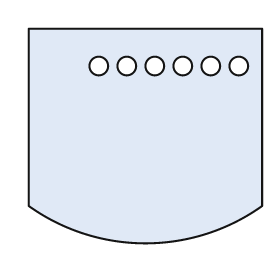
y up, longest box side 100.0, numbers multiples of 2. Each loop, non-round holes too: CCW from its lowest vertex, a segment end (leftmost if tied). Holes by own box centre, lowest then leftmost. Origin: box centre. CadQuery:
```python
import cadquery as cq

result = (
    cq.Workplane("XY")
    .moveTo(-50.0, -30.0)
    .threePointArc((0.0, -46.0), (50.0, -30.0))
    .lineTo(50.0, 46.0)
    .lineTo(-50.0, 46.0)
    .close()
    .moveTo(-20.0, 30.0)
    .circle(4.0)
    .moveTo(-8.0, 30.0)
    .circle(4.0)
    .moveTo(4.0, 30.0)
    .circle(4.0)
    .moveTo(16.0, 30.0)
    .circle(4.0)
    .moveTo(28.0, 30.0)
    .circle(4.0)
    .moveTo(40.0, 30.0)
    .circle(4.0)
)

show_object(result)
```